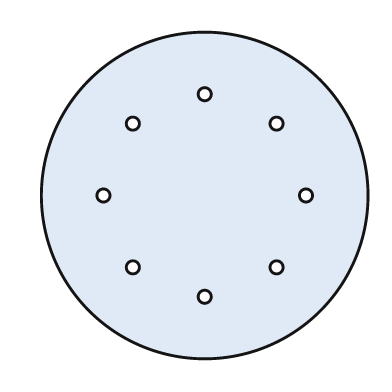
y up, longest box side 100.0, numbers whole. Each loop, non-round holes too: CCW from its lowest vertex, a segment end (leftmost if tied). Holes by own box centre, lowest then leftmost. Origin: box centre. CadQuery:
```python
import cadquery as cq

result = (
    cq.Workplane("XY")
    .moveTo(0.0, 0.0)
    .circle(50.0)
    .moveTo(0.0, -31.0)
    .circle(2.0)
    .moveTo(-22.0, -22.0)
    .circle(2.0)
    .moveTo(22.0, -22.0)
    .circle(2.0)
    .moveTo(-31.0, 0.0)
    .circle(2.0)
    .moveTo(31.0, 0.0)
    .circle(2.0)
    .moveTo(-22.0, 22.0)
    .circle(2.0)
    .moveTo(22.0, 22.0)
    .circle(2.0)
    .moveTo(0.0, 31.0)
    .circle(2.0)
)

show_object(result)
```